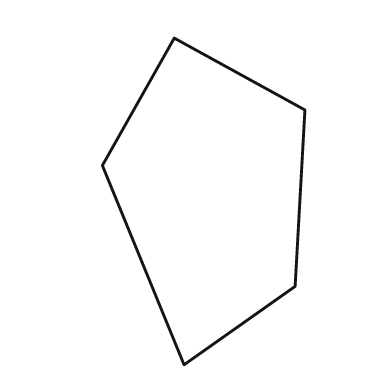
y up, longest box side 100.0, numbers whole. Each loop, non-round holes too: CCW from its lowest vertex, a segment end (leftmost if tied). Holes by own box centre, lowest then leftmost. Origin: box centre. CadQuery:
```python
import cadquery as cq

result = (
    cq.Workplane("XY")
    .moveTo(-6.0, -50.0)
    .lineTo(28.0, -26.0)
    .lineTo(31.0, 28.0)
    .lineTo(-9.0, 50.0)
    .lineTo(-31.0, 11.0)
    .close()
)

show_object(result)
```